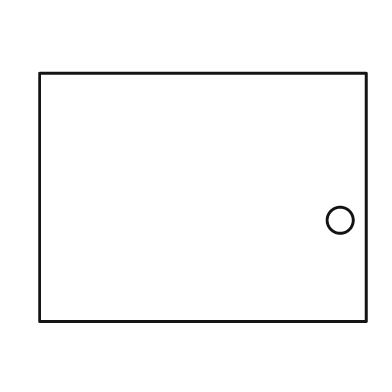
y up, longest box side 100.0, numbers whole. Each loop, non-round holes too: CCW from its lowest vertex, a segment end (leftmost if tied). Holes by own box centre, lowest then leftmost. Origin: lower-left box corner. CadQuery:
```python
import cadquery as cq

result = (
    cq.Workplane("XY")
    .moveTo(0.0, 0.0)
    .lineTo(100.0, 0.0)
    .lineTo(100.0, 76.0)
    .lineTo(0.0, 76.0)
    .close()
    .moveTo(92.0, 31.0)
    .circle(4.0)
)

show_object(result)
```